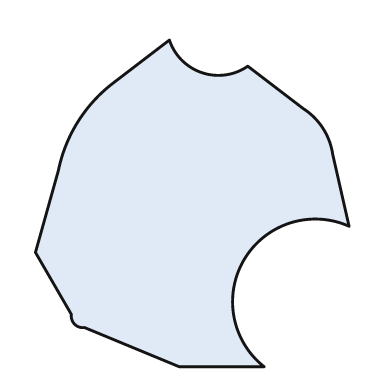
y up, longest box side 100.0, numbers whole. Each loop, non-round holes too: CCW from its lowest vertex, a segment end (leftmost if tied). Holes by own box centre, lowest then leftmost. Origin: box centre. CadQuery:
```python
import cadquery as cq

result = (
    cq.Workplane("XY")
    .moveTo(-4.0, -50.0)
    .lineTo(22.0, -50.0)
    .threePointArc((16.0, -17.0), (48.0, -7.0))
    .lineTo(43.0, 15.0)
    .threePointArc((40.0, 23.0), (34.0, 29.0))
    .lineTo(17.0, 42.0)
    .threePointArc((3.0, 40.0), (-7.0, 50.0))
    .lineTo(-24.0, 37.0)
    .threePointArc((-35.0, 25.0), (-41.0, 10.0))
    .lineTo(-48.0, -15.0)
    .lineTo(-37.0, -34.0)
    .threePointArc((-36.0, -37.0), (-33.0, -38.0))
    .close()
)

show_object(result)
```